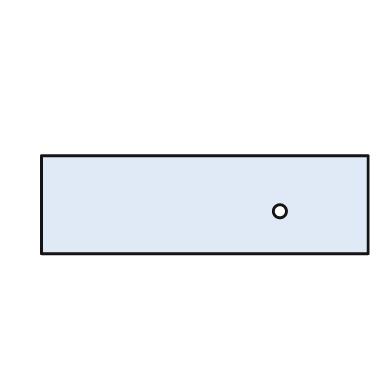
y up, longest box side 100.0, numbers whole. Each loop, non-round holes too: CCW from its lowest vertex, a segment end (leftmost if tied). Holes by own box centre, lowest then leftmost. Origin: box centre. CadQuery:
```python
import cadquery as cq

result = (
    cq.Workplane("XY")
    .moveTo(-50.0, -15.0)
    .lineTo(50.0, -15.0)
    .lineTo(50.0, 15.0)
    .lineTo(-50.0, 15.0)
    .close()
    .moveTo(23.0, -2.0)
    .circle(2.0)
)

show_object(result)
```